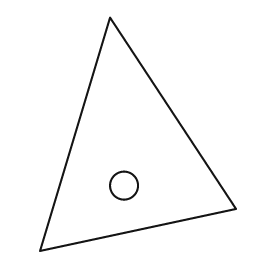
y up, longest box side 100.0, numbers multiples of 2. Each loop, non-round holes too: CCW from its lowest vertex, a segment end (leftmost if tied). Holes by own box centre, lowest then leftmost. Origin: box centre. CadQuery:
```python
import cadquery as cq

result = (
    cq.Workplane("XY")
    .moveTo(-42.0, -50.0)
    .lineTo(42.0, -32.0)
    .lineTo(-12.0, 50.0)
    .close()
    .moveTo(-6.0, -22.0)
    .circle(6.0)
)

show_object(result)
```